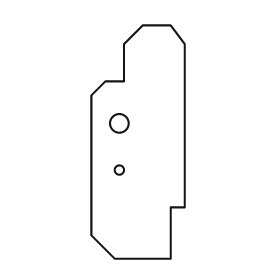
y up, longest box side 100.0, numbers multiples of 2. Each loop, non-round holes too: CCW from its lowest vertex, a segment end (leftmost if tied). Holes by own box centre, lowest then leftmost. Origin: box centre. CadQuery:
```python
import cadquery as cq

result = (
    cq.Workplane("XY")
    .moveTo(-10.0, -50.0)
    .lineTo(14.0, -50.0)
    .lineTo(14.0, -28.0)
    .lineTo(20.0, -28.0)
    .lineTo(20.0, 42.0)
    .lineTo(14.0, 50.0)
    .lineTo(2.0, 50.0)
    .lineTo(-6.0, 42.0)
    .lineTo(-6.0, 26.0)
    .lineTo(-14.0, 26.0)
    .lineTo(-20.0, 20.0)
    .lineTo(-20.0, -40.0)
    .close()
    .moveTo(-8.0, -12.0)
    .circle(2.0)
    .moveTo(-8.0, 8.0)
    .circle(4.0)
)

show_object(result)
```